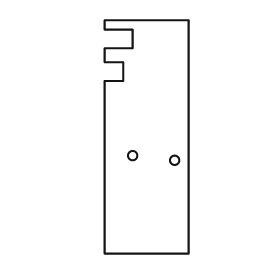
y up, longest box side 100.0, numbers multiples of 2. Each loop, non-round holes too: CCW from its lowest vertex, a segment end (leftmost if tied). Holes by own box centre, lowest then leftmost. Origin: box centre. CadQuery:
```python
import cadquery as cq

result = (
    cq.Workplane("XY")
    .moveTo(-18.0, -50.0)
    .lineTo(18.0, -50.0)
    .lineTo(18.0, 50.0)
    .lineTo(-18.0, 50.0)
    .lineTo(-18.0, 46.0)
    .lineTo(-6.0, 46.0)
    .lineTo(-6.0, 38.0)
    .lineTo(-18.0, 38.0)
    .lineTo(-18.0, 32.0)
    .lineTo(-10.0, 32.0)
    .lineTo(-10.0, 24.0)
    .lineTo(-18.0, 24.0)
    .close()
    .moveTo(12.0, -10.0)
    .circle(2.0)
    .moveTo(-6.0, -8.0)
    .circle(2.0)
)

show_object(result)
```